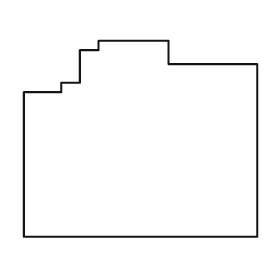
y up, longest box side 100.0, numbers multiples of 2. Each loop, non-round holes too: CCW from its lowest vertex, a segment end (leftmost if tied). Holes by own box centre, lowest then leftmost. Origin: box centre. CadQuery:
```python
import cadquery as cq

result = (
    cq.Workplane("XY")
    .moveTo(-50.0, -42.0)
    .lineTo(50.0, -42.0)
    .lineTo(50.0, 32.0)
    .lineTo(12.0, 32.0)
    .lineTo(12.0, 42.0)
    .lineTo(-18.0, 42.0)
    .lineTo(-18.0, 38.0)
    .lineTo(-26.0, 38.0)
    .lineTo(-26.0, 24.0)
    .lineTo(-34.0, 24.0)
    .lineTo(-34.0, 20.0)
    .lineTo(-50.0, 20.0)
    .close()
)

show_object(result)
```